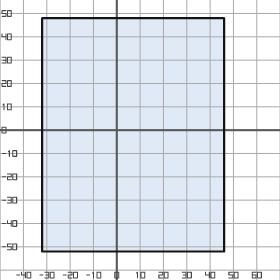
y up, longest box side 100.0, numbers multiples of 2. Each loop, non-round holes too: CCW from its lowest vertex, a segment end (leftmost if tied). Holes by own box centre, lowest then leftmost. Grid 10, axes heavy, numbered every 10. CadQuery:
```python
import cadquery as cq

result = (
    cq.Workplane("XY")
    .moveTo(-32.0, -52.0)
    .lineTo(46.0, -52.0)
    .lineTo(46.0, 48.0)
    .lineTo(-32.0, 48.0)
    .close()
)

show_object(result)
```